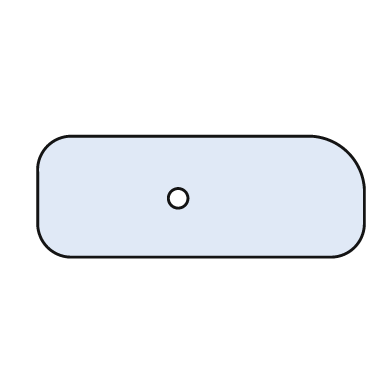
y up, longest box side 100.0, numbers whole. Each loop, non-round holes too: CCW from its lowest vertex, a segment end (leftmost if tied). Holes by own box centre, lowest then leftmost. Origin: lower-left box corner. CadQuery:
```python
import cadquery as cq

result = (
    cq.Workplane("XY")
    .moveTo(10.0, 0.0)
    .lineTo(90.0, 0.0)
    .threePointArc((97.0, 3.0), (100.0, 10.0))
    .lineTo(100.0, 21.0)
    .threePointArc((95.0, 32.0), (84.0, 37.0))
    .lineTo(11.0, 37.0)
    .threePointArc((3.0, 34.0), (0.0, 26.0))
    .lineTo(0.0, 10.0)
    .threePointArc((3.0, 3.0), (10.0, 0.0))
    .close()
    .moveTo(43.0, 18.0)
    .circle(3.0)
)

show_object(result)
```